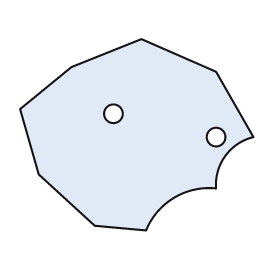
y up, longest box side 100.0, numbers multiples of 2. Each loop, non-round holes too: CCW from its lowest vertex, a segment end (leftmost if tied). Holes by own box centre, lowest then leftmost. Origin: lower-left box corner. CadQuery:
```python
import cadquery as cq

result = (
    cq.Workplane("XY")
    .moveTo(54.0, 0.0)
    .threePointArc((66.0, 14.0), (84.0, 18.0))
    .threePointArc((88.0, 32.0), (100.0, 40.0))
    .lineTo(84.0, 68.0)
    .lineTo(52.0, 82.0)
    .lineTo(22.0, 70.0)
    .lineTo(0.0, 52.0)
    .lineTo(8.0, 24.0)
    .lineTo(32.0, 2.0)
    .close()
    .moveTo(84.0, 40.0)
    .circle(4.0)
    .moveTo(40.0, 50.0)
    .circle(4.0)
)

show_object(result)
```